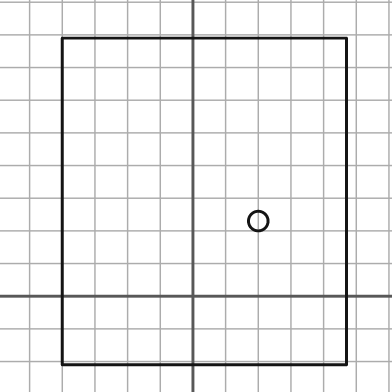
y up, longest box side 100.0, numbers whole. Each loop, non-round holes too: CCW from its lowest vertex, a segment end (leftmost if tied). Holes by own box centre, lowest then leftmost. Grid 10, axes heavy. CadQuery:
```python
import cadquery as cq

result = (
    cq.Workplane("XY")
    .moveTo(-40.0, -21.0)
    .lineTo(47.0, -21.0)
    .lineTo(47.0, 79.0)
    .lineTo(-40.0, 79.0)
    .close()
    .moveTo(20.0, 23.0)
    .circle(3.0)
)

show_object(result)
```